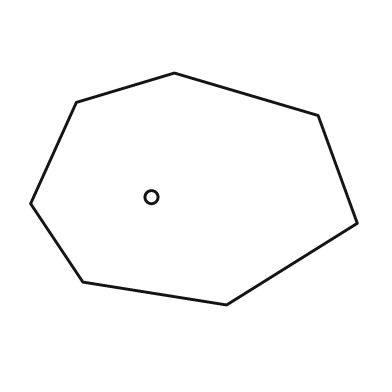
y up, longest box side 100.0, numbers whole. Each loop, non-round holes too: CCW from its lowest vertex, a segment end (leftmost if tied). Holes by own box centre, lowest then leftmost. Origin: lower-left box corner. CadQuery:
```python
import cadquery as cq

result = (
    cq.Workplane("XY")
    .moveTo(60.0, 0.0)
    .lineTo(100.0, 25.0)
    .lineTo(88.0, 58.0)
    .lineTo(44.0, 71.0)
    .lineTo(14.0, 62.0)
    .lineTo(0.0, 31.0)
    .lineTo(16.0, 7.0)
    .close()
    .moveTo(37.0, 33.0)
    .circle(2.0)
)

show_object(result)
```